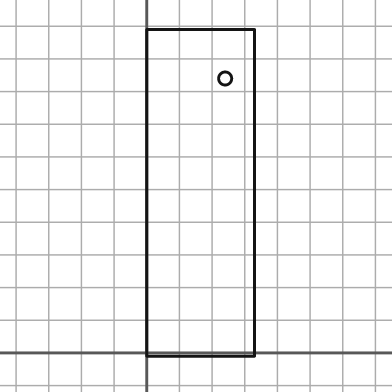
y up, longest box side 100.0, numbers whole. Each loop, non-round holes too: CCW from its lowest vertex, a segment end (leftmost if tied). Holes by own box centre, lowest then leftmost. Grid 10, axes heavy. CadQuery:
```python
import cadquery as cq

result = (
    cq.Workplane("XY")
    .moveTo(0.0, -1.0)
    .lineTo(33.0, -1.0)
    .lineTo(33.0, 99.0)
    .lineTo(0.0, 99.0)
    .close()
    .moveTo(24.0, 84.0)
    .circle(2.0)
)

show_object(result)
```